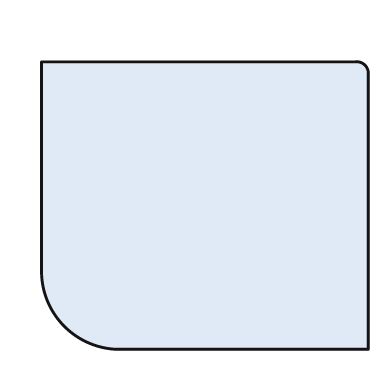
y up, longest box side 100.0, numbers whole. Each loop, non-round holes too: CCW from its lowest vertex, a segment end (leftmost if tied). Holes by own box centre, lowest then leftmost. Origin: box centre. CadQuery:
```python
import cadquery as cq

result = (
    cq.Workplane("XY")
    .moveTo(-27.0, -44.0)
    .lineTo(50.0, -44.0)
    .lineTo(50.0, 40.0)
    .threePointArc((49.0, 43.0), (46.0, 44.0))
    .lineTo(-50.0, 44.0)
    .lineTo(-50.0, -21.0)
    .threePointArc((-43.0, -37.0), (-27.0, -44.0))
    .close()
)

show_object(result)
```